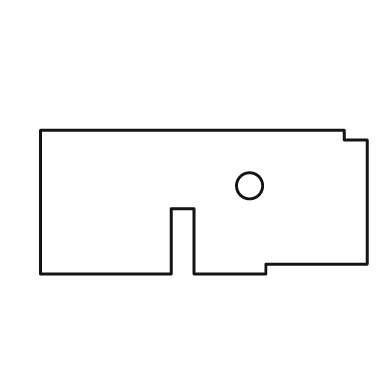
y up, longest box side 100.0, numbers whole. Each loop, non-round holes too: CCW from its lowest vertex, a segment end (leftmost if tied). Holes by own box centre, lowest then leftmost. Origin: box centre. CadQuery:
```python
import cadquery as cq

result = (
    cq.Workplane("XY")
    .moveTo(-50.0, -22.0)
    .lineTo(-10.0, -22.0)
    .lineTo(-10.0, -2.0)
    .lineTo(-3.0, -2.0)
    .lineTo(-3.0, -22.0)
    .lineTo(19.0, -22.0)
    .lineTo(19.0, -19.0)
    .lineTo(50.0, -19.0)
    .lineTo(50.0, 19.0)
    .lineTo(43.0, 19.0)
    .lineTo(43.0, 22.0)
    .lineTo(-50.0, 22.0)
    .close()
    .moveTo(14.0, 5.0)
    .circle(4.0)
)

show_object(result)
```